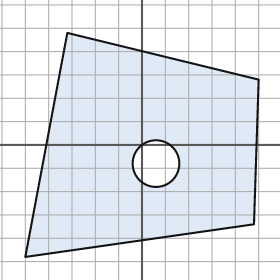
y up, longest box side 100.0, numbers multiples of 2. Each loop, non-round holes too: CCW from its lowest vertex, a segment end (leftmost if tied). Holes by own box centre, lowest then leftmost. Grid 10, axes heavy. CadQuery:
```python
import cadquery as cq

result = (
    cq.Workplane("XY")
    .moveTo(-50.0, -48.0)
    .lineTo(48.0, -34.0)
    .lineTo(50.0, 28.0)
    .lineTo(-32.0, 48.0)
    .close()
    .moveTo(6.0, -8.0)
    .circle(10.0)
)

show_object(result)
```